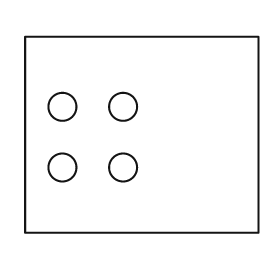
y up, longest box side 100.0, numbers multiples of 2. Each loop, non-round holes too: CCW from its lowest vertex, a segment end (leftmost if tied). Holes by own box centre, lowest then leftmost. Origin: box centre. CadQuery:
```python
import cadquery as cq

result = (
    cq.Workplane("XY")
    .moveTo(-50.0, -42.0)
    .lineTo(50.0, -42.0)
    .lineTo(50.0, 42.0)
    .lineTo(-50.0, 42.0)
    .close()
    .moveTo(-34.0, -14.0)
    .circle(6.0)
    .moveTo(-8.0, -14.0)
    .circle(6.0)
    .moveTo(-34.0, 12.0)
    .circle(6.0)
    .moveTo(-8.0, 12.0)
    .circle(6.0)
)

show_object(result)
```